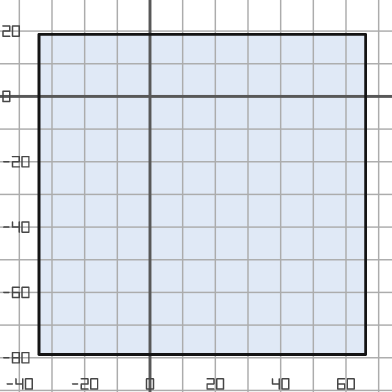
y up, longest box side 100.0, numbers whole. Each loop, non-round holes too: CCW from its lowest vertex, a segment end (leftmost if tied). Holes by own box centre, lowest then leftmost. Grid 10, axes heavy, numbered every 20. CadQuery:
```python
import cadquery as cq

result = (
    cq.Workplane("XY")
    .moveTo(-34.0, -79.0)
    .lineTo(66.0, -79.0)
    .lineTo(66.0, 19.0)
    .lineTo(-34.0, 19.0)
    .close()
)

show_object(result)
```